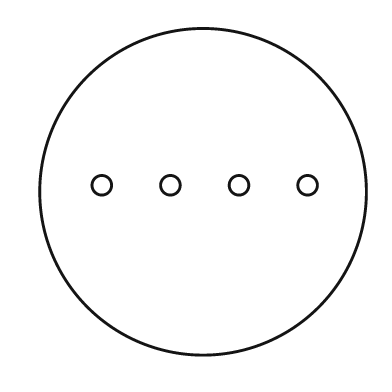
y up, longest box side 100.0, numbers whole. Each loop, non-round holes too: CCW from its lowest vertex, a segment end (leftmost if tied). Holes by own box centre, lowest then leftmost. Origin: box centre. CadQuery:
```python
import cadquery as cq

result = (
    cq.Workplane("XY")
    .moveTo(0.0, 0.0)
    .circle(50.0)
    .moveTo(-31.0, 2.0)
    .circle(3.0)
    .moveTo(-10.0, 2.0)
    .circle(3.0)
    .moveTo(11.0, 2.0)
    .circle(3.0)
    .moveTo(32.0, 2.0)
    .circle(3.0)
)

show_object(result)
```